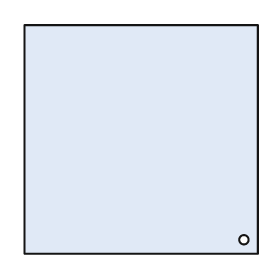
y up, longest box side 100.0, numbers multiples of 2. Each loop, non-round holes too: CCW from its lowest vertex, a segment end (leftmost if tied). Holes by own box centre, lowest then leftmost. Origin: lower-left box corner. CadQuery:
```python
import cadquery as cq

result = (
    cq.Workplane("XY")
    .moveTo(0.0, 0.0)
    .lineTo(100.0, 0.0)
    .lineTo(100.0, 98.0)
    .lineTo(0.0, 98.0)
    .close()
    .moveTo(94.0, 6.0)
    .circle(2.0)
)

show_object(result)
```